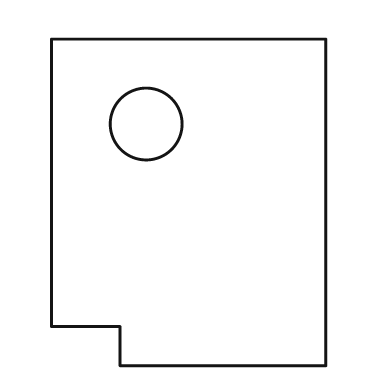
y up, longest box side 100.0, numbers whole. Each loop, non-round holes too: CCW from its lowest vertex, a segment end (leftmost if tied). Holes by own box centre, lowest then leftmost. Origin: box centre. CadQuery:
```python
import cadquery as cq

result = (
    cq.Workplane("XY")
    .moveTo(-21.0, -50.0)
    .lineTo(42.0, -50.0)
    .lineTo(42.0, 50.0)
    .lineTo(-42.0, 50.0)
    .lineTo(-42.0, -38.0)
    .lineTo(-21.0, -38.0)
    .close()
    .moveTo(-13.0, 24.0)
    .circle(11.0)
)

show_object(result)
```